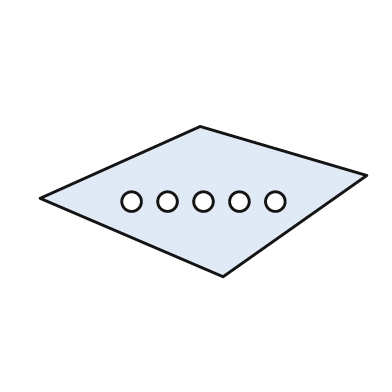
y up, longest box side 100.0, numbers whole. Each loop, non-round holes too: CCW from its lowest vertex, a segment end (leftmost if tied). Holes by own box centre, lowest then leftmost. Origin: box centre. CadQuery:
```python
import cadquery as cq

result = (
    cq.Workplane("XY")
    .moveTo(6.0, -23.0)
    .lineTo(50.0, 8.0)
    .lineTo(-1.0, 23.0)
    .lineTo(-50.0, 1.0)
    .close()
    .moveTo(-22.0, 0.0)
    .circle(3.0)
    .moveTo(-11.0, 0.0)
    .circle(3.0)
    .moveTo(0.0, 0.0)
    .circle(3.0)
    .moveTo(11.0, 0.0)
    .circle(3.0)
    .moveTo(22.0, 0.0)
    .circle(3.0)
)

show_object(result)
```